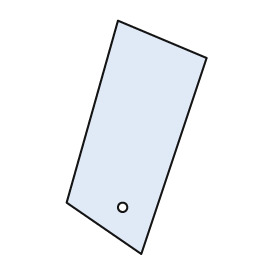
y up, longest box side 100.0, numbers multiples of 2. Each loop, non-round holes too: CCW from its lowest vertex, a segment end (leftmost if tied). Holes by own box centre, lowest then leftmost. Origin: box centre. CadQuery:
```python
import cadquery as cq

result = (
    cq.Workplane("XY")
    .moveTo(2.0, -50.0)
    .lineTo(30.0, 34.0)
    .lineTo(-8.0, 50.0)
    .lineTo(-30.0, -28.0)
    .close()
    .moveTo(-6.0, -30.0)
    .circle(2.0)
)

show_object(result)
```